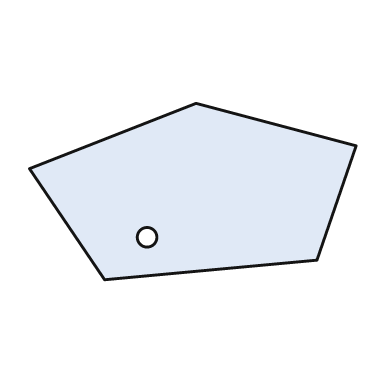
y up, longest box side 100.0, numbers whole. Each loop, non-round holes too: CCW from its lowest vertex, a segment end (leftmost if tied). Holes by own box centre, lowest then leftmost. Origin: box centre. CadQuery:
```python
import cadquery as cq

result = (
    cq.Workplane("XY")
    .moveTo(-27.0, -27.0)
    .lineTo(38.0, -21.0)
    .lineTo(50.0, 14.0)
    .lineTo(1.0, 27.0)
    .lineTo(-50.0, 7.0)
    .close()
    .moveTo(-14.0, -14.0)
    .circle(3.0)
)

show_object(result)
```